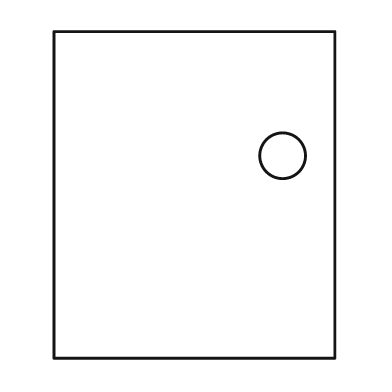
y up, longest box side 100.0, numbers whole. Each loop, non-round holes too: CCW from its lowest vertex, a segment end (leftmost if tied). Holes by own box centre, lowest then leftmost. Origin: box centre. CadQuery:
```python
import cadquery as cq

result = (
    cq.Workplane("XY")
    .moveTo(-43.0, -50.0)
    .lineTo(43.0, -50.0)
    .lineTo(43.0, 50.0)
    .lineTo(-43.0, 50.0)
    .close()
    .moveTo(27.0, 12.0)
    .circle(7.0)
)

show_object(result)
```